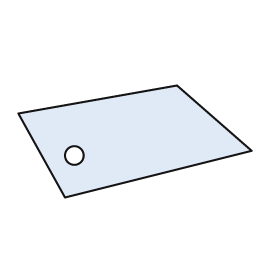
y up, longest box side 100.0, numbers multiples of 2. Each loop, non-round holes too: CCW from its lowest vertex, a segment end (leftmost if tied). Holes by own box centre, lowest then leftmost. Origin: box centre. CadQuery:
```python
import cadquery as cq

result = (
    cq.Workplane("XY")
    .moveTo(-30.0, -24.0)
    .lineTo(50.0, -4.0)
    .lineTo(18.0, 24.0)
    .lineTo(-50.0, 12.0)
    .close()
    .moveTo(-26.0, -6.0)
    .circle(4.0)
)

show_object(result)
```